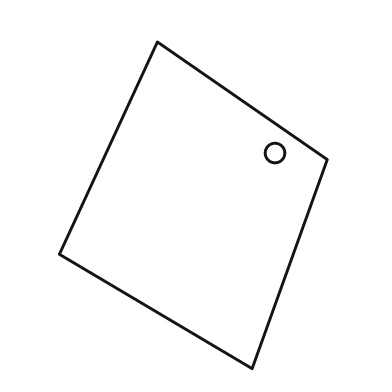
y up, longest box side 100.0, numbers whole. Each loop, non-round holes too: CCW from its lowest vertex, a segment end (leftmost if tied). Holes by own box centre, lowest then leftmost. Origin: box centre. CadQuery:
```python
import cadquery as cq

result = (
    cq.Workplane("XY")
    .moveTo(18.0, -50.0)
    .lineTo(41.0, 14.0)
    .lineTo(-11.0, 50.0)
    .lineTo(-41.0, -15.0)
    .close()
    .moveTo(25.0, 16.0)
    .circle(3.0)
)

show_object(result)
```